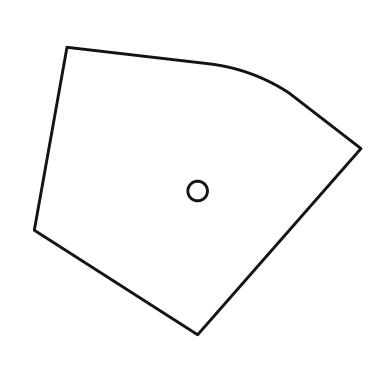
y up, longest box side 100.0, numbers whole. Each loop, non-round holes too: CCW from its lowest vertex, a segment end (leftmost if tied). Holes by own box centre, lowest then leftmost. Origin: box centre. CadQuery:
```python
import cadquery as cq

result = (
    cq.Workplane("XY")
    .moveTo(0.0, -44.0)
    .lineTo(50.0, 13.0)
    .lineTo(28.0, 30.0)
    .threePointArc((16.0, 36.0), (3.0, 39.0))
    .lineTo(-40.0, 44.0)
    .lineTo(-50.0, -12.0)
    .close()
    .moveTo(0.0, 0.0)
    .circle(3.0)
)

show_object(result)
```